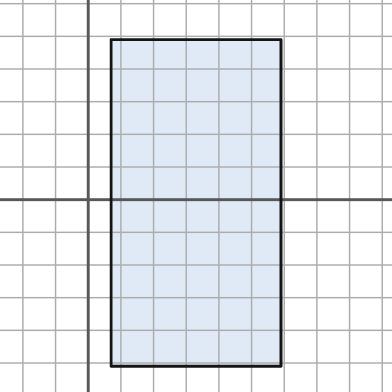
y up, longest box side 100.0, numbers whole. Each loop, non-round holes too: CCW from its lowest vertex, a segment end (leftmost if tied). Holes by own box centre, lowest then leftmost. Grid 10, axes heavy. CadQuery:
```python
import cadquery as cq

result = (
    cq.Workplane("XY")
    .moveTo(7.0, -51.0)
    .lineTo(59.0, -51.0)
    .lineTo(59.0, 49.0)
    .lineTo(7.0, 49.0)
    .close()
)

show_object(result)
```